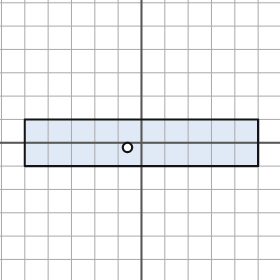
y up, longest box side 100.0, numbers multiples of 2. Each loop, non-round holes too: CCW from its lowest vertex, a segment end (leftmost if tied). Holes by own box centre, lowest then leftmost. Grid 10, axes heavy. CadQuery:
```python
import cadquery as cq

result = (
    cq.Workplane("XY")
    .moveTo(-50.0, -10.0)
    .lineTo(50.0, -10.0)
    .lineTo(50.0, 10.0)
    .lineTo(-50.0, 10.0)
    .close()
    .moveTo(-6.0, -2.0)
    .circle(2.0)
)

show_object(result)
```